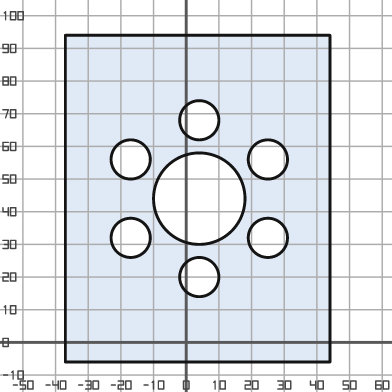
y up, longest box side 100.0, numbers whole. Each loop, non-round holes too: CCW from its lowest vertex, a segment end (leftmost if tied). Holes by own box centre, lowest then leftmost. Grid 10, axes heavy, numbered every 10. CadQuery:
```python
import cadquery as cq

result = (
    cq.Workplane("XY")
    .moveTo(-37.0, -6.0)
    .lineTo(44.0, -6.0)
    .lineTo(44.0, 94.0)
    .lineTo(-37.0, 94.0)
    .close()
    .moveTo(4.0, 20.0)
    .circle(6.0)
    .moveTo(-17.0, 32.0)
    .circle(6.0)
    .moveTo(25.0, 32.0)
    .circle(6.0)
    .moveTo(4.0, 44.0)
    .circle(14.0)
    .moveTo(-17.0, 56.0)
    .circle(6.0)
    .moveTo(25.0, 56.0)
    .circle(6.0)
    .moveTo(4.0, 68.0)
    .circle(6.0)
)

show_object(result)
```